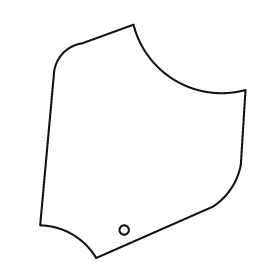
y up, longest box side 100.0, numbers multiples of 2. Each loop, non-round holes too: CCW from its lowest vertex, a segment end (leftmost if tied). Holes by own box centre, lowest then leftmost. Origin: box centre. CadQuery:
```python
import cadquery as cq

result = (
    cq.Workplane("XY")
    .moveTo(-20.0, -50.0)
    .lineTo(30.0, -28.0)
    .threePointArc((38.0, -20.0), (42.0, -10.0))
    .lineTo(44.0, 22.0)
    .threePointArc((14.0, 26.0), (-4.0, 50.0))
    .lineTo(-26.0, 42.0)
    .threePointArc((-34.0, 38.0), (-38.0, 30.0))
    .lineTo(-44.0, -36.0)
    .threePointArc((-30.0, -40.0), (-20.0, -50.0))
    .close()
    .moveTo(-8.0, -38.0)
    .circle(2.0)
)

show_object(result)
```